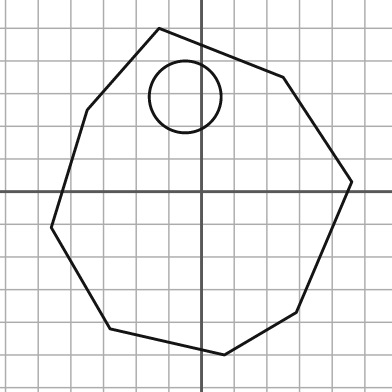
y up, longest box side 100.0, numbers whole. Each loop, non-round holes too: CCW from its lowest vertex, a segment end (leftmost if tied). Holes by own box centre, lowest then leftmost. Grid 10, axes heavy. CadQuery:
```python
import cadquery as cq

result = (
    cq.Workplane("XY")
    .moveTo(7.0, -50.0)
    .lineTo(29.0, -37.0)
    .lineTo(46.0, 3.0)
    .lineTo(25.0, 35.0)
    .lineTo(-13.0, 50.0)
    .lineTo(-35.0, 25.0)
    .lineTo(-46.0, -11.0)
    .lineTo(-28.0, -42.0)
    .close()
    .moveTo(-5.0, 29.0)
    .circle(11.0)
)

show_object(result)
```